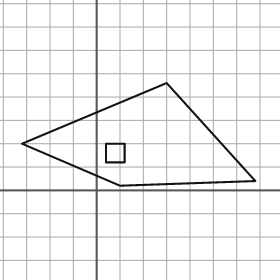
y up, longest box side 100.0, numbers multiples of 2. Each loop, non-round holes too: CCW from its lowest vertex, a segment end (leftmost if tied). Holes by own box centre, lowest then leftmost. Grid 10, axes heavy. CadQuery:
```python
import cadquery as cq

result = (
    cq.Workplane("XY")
    .moveTo(10.0, 2.0)
    .lineTo(68.0, 4.0)
    .lineTo(30.0, 46.0)
    .lineTo(-32.0, 20.0)
    .close()
    .moveTo(4.0, 12.0)
    .lineTo(12.0, 12.0)
    .lineTo(12.0, 20.0)
    .lineTo(4.0, 20.0)
    .close()
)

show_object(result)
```